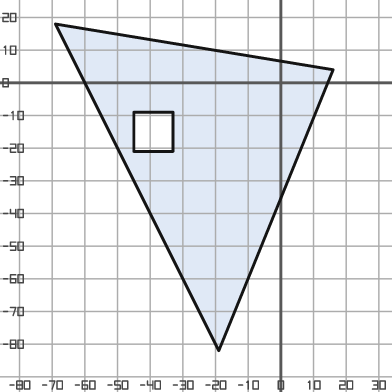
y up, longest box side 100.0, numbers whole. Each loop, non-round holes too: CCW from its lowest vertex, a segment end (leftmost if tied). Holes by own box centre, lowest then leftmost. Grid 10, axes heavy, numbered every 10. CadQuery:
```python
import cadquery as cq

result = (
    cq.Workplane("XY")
    .moveTo(-19.0, -82.0)
    .lineTo(16.0, 4.0)
    .lineTo(-69.0, 18.0)
    .close()
    .moveTo(-45.0, -21.0)
    .lineTo(-33.0, -21.0)
    .lineTo(-33.0, -9.0)
    .lineTo(-45.0, -9.0)
    .close()
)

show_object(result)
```